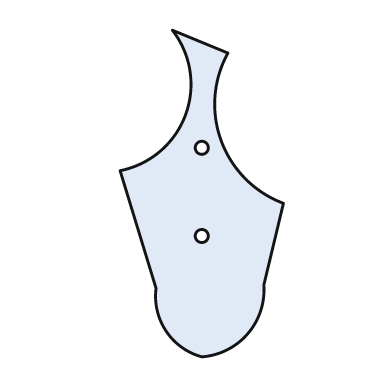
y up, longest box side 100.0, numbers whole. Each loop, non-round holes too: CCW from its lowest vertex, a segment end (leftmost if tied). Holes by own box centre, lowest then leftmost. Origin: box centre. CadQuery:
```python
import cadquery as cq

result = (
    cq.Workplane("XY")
    .moveTo(0.0, -50.0)
    .threePointArc((14.0, -43.0), (19.0, -28.0))
    .lineTo(25.0, -3.0)
    .threePointArc((6.0, 16.0), (8.0, 43.0))
    .lineTo(-9.0, 50.0)
    .threePointArc((-5.0, 24.0), (-25.0, 7.0))
    .lineTo(-14.0, -29.0)
    .threePointArc((-11.0, -42.0), (0.0, -50.0))
    .close()
    .moveTo(0.0, -13.0)
    .circle(2.0)
    .moveTo(0.0, 14.0)
    .circle(2.0)
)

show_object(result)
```